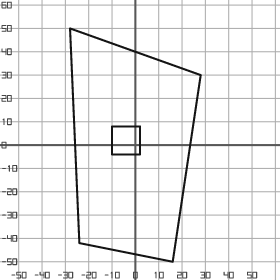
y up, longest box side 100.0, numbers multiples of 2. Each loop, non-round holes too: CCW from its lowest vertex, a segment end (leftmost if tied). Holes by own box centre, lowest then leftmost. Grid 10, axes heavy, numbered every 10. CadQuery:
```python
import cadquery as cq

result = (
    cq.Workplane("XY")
    .moveTo(16.0, -50.0)
    .lineTo(28.0, 30.0)
    .lineTo(-28.0, 50.0)
    .lineTo(-24.0, -42.0)
    .close()
    .moveTo(-10.0, -4.0)
    .lineTo(2.0, -4.0)
    .lineTo(2.0, 8.0)
    .lineTo(-10.0, 8.0)
    .close()
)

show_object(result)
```